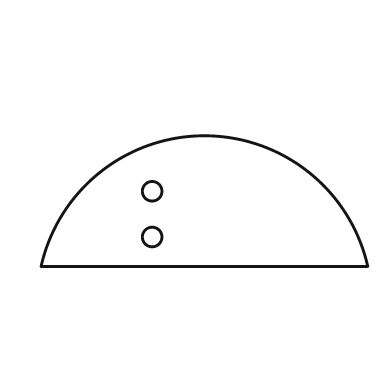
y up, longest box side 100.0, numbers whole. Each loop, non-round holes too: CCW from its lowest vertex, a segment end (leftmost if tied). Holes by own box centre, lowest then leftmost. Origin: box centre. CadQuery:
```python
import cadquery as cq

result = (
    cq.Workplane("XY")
    .moveTo(-50.0, -20.0)
    .lineTo(50.0, -20.0)
    .threePointArc((0.0, 20.0), (-50.0, -20.0))
    .close()
    .moveTo(-16.0, -11.0)
    .circle(3.0)
    .moveTo(-16.0, 3.0)
    .circle(3.0)
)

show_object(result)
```